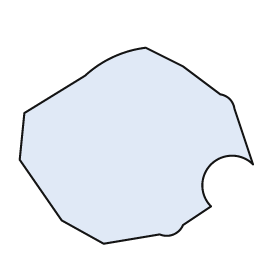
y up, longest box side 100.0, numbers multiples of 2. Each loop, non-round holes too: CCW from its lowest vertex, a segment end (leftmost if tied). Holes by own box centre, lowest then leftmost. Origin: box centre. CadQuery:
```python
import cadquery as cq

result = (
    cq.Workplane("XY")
    .moveTo(-14.0, -42.0)
    .lineTo(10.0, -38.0)
    .threePointArc((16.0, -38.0), (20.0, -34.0))
    .lineTo(32.0, -26.0)
    .threePointArc((32.0, -8.0), (50.0, -8.0))
    .lineTo(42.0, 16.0)
    .threePointArc((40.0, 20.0), (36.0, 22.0))
    .lineTo(20.0, 34.0)
    .lineTo(4.0, 42.0)
    .threePointArc((-10.0, 38.0), (-22.0, 30.0))
    .lineTo(-48.0, 14.0)
    .lineTo(-50.0, -6.0)
    .lineTo(-32.0, -32.0)
    .close()
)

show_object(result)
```